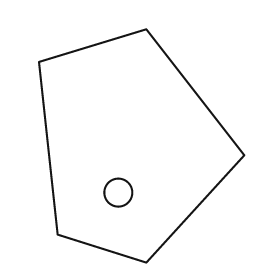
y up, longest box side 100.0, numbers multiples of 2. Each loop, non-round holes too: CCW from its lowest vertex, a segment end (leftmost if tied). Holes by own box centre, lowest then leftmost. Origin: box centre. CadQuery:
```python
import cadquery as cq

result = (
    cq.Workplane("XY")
    .moveTo(2.0, -50.0)
    .lineTo(44.0, -4.0)
    .lineTo(2.0, 50.0)
    .lineTo(-44.0, 36.0)
    .lineTo(-36.0, -38.0)
    .close()
    .moveTo(-10.0, -20.0)
    .circle(6.0)
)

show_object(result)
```